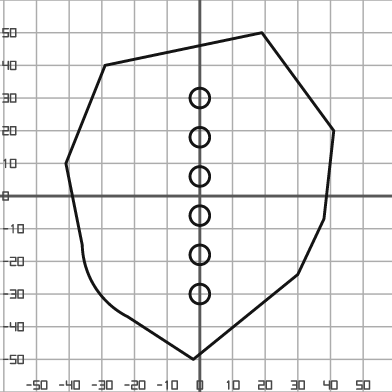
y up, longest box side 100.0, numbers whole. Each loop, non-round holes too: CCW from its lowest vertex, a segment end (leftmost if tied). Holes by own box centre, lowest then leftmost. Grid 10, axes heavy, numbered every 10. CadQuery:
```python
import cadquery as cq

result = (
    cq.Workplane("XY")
    .moveTo(-2.0, -50.0)
    .lineTo(30.0, -24.0)
    .lineTo(38.0, -7.0)
    .lineTo(41.0, 20.0)
    .lineTo(19.0, 50.0)
    .lineTo(-29.0, 40.0)
    .lineTo(-41.0, 10.0)
    .lineTo(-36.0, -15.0)
    .threePointArc((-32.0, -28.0), (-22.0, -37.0))
    .close()
    .moveTo(0.0, -30.0)
    .circle(3.0)
    .moveTo(0.0, -18.0)
    .circle(3.0)
    .moveTo(0.0, -6.0)
    .circle(3.0)
    .moveTo(0.0, 6.0)
    .circle(3.0)
    .moveTo(0.0, 18.0)
    .circle(3.0)
    .moveTo(0.0, 30.0)
    .circle(3.0)
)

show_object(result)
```